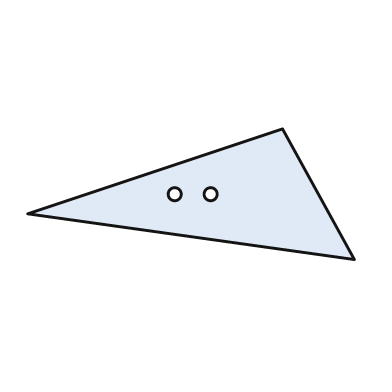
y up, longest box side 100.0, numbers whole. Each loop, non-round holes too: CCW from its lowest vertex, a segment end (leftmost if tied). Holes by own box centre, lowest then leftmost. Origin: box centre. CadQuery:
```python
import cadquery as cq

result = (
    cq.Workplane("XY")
    .moveTo(50.0, -20.0)
    .lineTo(28.0, 20.0)
    .lineTo(-50.0, -6.0)
    .close()
    .moveTo(-5.0, 0.0)
    .circle(2.0)
    .moveTo(6.0, 0.0)
    .circle(2.0)
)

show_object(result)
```